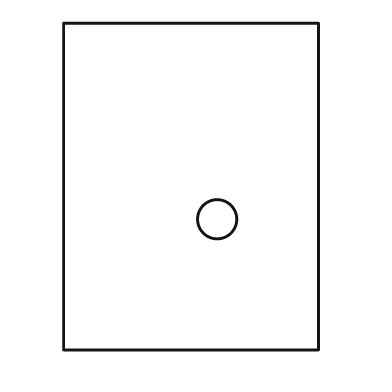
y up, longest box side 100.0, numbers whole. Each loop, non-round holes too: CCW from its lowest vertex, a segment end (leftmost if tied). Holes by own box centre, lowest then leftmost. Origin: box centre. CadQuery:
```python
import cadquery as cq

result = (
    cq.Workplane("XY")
    .moveTo(-39.0, -50.0)
    .lineTo(39.0, -50.0)
    .lineTo(39.0, 50.0)
    .lineTo(-39.0, 50.0)
    .close()
    .moveTo(8.0, -10.0)
    .circle(6.0)
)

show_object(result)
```